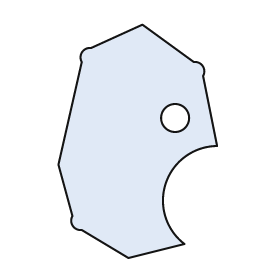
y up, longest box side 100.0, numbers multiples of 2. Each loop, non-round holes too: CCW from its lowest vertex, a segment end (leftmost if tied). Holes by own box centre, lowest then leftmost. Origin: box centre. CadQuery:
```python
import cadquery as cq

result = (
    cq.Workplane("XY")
    .moveTo(-4.0, -50.0)
    .lineTo(20.0, -44.0)
    .threePointArc((12.0, -18.0), (34.0, -2.0))
    .lineTo(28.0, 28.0)
    .threePointArc((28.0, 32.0), (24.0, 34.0))
    .lineTo(2.0, 50.0)
    .lineTo(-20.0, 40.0)
    .threePointArc((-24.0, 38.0), (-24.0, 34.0))
    .lineTo(-34.0, -10.0)
    .lineTo(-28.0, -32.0)
    .threePointArc((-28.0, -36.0), (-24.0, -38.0))
    .close()
    .moveTo(16.0, 10.0)
    .circle(6.0)
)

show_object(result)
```